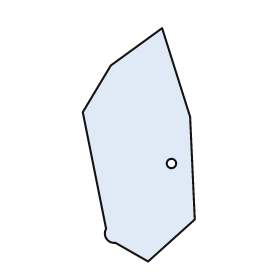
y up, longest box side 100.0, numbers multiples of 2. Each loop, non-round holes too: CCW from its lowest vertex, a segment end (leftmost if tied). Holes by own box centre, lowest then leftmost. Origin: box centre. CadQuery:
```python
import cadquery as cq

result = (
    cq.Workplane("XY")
    .moveTo(4.0, -50.0)
    .lineTo(24.0, -32.0)
    .lineTo(22.0, 12.0)
    .lineTo(10.0, 50.0)
    .lineTo(-12.0, 34.0)
    .lineTo(-24.0, 14.0)
    .lineTo(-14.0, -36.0)
    .threePointArc((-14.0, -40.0), (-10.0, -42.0))
    .close()
    .moveTo(14.0, -8.0)
    .circle(2.0)
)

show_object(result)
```